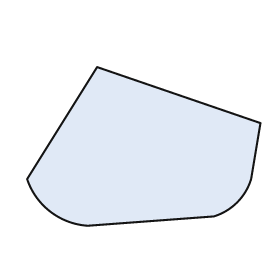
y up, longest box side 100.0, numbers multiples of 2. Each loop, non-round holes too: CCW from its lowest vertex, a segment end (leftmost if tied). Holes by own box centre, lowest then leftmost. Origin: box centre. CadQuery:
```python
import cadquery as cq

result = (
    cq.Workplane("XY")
    .moveTo(-24.0, -34.0)
    .lineTo(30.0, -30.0)
    .threePointArc((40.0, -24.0), (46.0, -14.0))
    .lineTo(50.0, 10.0)
    .lineTo(-20.0, 34.0)
    .lineTo(-50.0, -14.0)
    .threePointArc((-40.0, -28.0), (-24.0, -34.0))
    .close()
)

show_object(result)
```